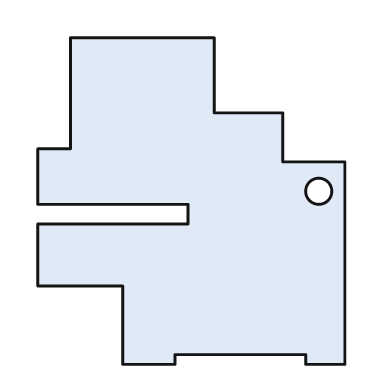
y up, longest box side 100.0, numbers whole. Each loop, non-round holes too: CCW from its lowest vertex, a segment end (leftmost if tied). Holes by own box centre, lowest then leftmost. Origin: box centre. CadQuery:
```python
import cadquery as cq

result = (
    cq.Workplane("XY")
    .moveTo(-21.0, -50.0)
    .lineTo(-5.0, -50.0)
    .lineTo(-5.0, -47.0)
    .lineTo(35.0, -47.0)
    .lineTo(35.0, -50.0)
    .lineTo(47.0, -50.0)
    .lineTo(47.0, 12.0)
    .lineTo(28.0, 12.0)
    .lineTo(28.0, 27.0)
    .lineTo(7.0, 27.0)
    .lineTo(7.0, 50.0)
    .lineTo(-37.0, 50.0)
    .lineTo(-37.0, 16.0)
    .lineTo(-47.0, 16.0)
    .lineTo(-47.0, -1.0)
    .lineTo(-1.0, -1.0)
    .lineTo(-1.0, -7.0)
    .lineTo(-47.0, -7.0)
    .lineTo(-47.0, -26.0)
    .lineTo(-21.0, -26.0)
    .close()
    .moveTo(39.0, 3.0)
    .circle(4.0)
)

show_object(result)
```